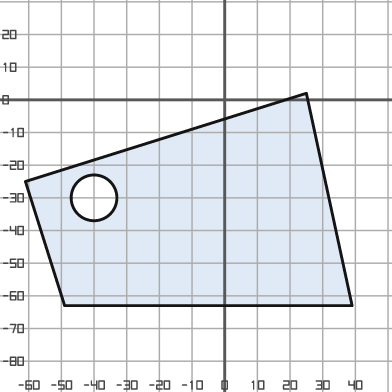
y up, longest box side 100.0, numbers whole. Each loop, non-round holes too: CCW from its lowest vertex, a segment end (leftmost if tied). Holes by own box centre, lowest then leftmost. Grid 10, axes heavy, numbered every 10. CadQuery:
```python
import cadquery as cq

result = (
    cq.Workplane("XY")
    .moveTo(-49.0, -63.0)
    .lineTo(39.0, -63.0)
    .lineTo(25.0, 2.0)
    .lineTo(-61.0, -25.0)
    .close()
    .moveTo(-40.0, -30.0)
    .circle(7.0)
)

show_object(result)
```